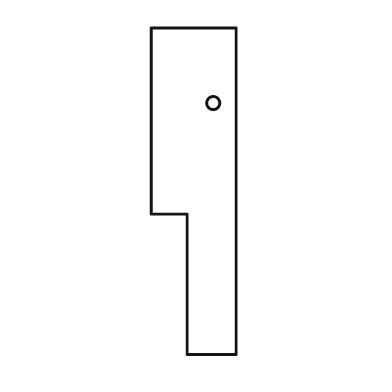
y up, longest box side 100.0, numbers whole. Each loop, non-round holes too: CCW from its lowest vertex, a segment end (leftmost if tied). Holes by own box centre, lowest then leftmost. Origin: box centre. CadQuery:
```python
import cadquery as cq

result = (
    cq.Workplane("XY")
    .moveTo(-2.0, -50.0)
    .lineTo(13.0, -50.0)
    .lineTo(13.0, 50.0)
    .lineTo(-13.0, 50.0)
    .lineTo(-13.0, -7.0)
    .lineTo(-2.0, -7.0)
    .close()
    .moveTo(6.0, 27.0)
    .circle(2.0)
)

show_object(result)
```